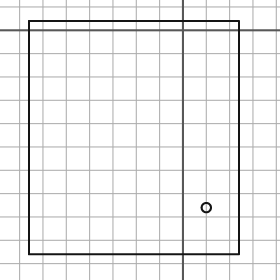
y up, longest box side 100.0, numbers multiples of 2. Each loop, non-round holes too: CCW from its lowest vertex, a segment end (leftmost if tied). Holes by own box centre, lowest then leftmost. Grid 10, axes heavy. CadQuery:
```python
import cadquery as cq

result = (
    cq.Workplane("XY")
    .moveTo(-66.0, -96.0)
    .lineTo(24.0, -96.0)
    .lineTo(24.0, 4.0)
    .lineTo(-66.0, 4.0)
    .close()
    .moveTo(10.0, -76.0)
    .circle(2.0)
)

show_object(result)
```